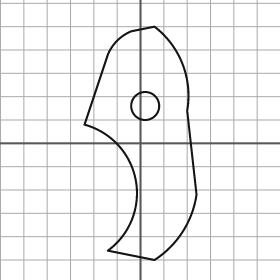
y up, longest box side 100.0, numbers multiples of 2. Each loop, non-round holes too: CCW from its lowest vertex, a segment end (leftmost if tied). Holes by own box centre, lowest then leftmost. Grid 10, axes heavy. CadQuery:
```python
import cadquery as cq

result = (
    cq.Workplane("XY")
    .moveTo(6.0, -50.0)
    .threePointArc((18.0, -38.0), (24.0, -22.0))
    .lineTo(20.0, 14.0)
    .threePointArc((18.0, 34.0), (6.0, 50.0))
    .lineTo(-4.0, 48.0)
    .threePointArc((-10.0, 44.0), (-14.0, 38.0))
    .lineTo(-24.0, 8.0)
    .threePointArc((-2.0, -16.0), (-14.0, -46.0))
    .close()
    .moveTo(2.0, 16.0)
    .circle(6.0)
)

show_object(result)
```